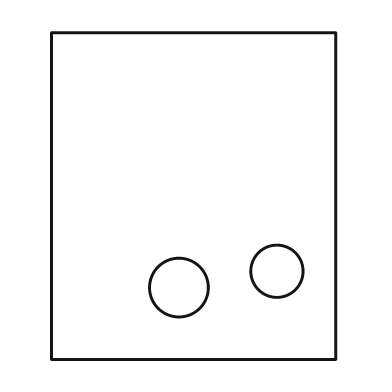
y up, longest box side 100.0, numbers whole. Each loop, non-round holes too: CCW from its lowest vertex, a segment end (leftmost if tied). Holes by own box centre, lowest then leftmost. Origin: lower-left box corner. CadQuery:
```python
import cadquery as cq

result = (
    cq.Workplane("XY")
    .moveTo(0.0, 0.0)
    .lineTo(87.0, 0.0)
    .lineTo(87.0, 100.0)
    .lineTo(0.0, 100.0)
    .close()
    .moveTo(39.0, 22.0)
    .circle(9.0)
    .moveTo(69.0, 27.0)
    .circle(8.0)
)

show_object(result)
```